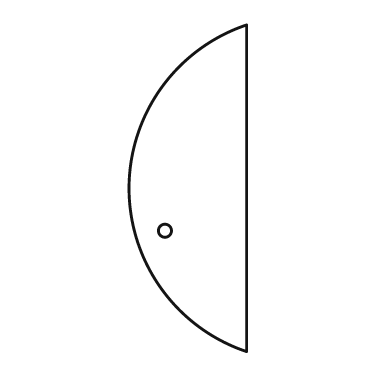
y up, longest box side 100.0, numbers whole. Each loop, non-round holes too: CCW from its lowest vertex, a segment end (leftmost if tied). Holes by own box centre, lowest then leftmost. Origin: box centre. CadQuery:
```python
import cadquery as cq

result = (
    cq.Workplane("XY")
    .moveTo(18.0, -50.0)
    .lineTo(18.0, 50.0)
    .threePointArc((-18.0, 0.0), (18.0, -50.0))
    .close()
    .moveTo(-7.0, -13.0)
    .circle(2.0)
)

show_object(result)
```